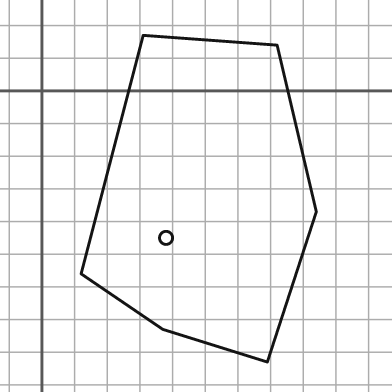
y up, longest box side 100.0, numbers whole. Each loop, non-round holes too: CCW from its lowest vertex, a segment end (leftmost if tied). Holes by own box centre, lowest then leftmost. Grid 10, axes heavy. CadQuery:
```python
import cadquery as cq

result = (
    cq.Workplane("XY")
    .moveTo(69.0, -83.0)
    .lineTo(84.0, -37.0)
    .lineTo(72.0, 14.0)
    .lineTo(31.0, 17.0)
    .lineTo(12.0, -56.0)
    .lineTo(37.0, -73.0)
    .close()
    .moveTo(38.0, -45.0)
    .circle(2.0)
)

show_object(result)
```